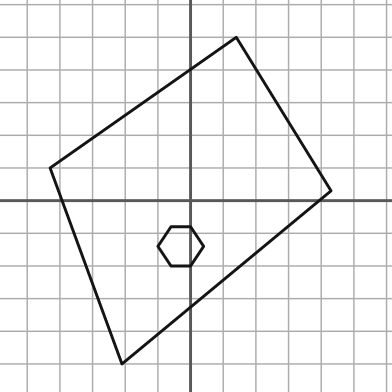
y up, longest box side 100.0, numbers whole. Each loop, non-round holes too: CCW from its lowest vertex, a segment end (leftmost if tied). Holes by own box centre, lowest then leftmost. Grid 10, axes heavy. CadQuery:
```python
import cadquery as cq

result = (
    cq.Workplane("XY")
    .moveTo(-21.0, -50.0)
    .lineTo(43.0, 3.0)
    .lineTo(14.0, 50.0)
    .lineTo(-43.0, 10.0)
    .close()
    .moveTo(-6.0, -20.0)
    .lineTo(0.0, -20.0)
    .lineTo(4.0, -14.0)
    .lineTo(0.0, -8.0)
    .lineTo(-6.0, -8.0)
    .lineTo(-10.0, -14.0)
    .close()
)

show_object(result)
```